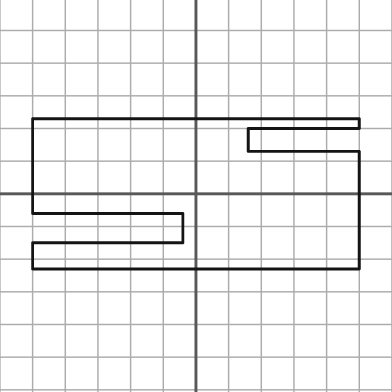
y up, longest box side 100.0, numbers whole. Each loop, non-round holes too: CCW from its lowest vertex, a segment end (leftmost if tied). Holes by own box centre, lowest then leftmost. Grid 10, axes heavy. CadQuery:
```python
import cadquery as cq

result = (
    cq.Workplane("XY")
    .moveTo(-50.0, -23.0)
    .lineTo(50.0, -23.0)
    .lineTo(50.0, 13.0)
    .lineTo(16.0, 13.0)
    .lineTo(16.0, 20.0)
    .lineTo(50.0, 20.0)
    .lineTo(50.0, 23.0)
    .lineTo(-50.0, 23.0)
    .lineTo(-50.0, -6.0)
    .lineTo(-4.0, -6.0)
    .lineTo(-4.0, -15.0)
    .lineTo(-50.0, -15.0)
    .close()
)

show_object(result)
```